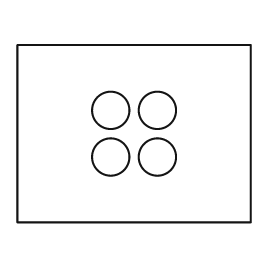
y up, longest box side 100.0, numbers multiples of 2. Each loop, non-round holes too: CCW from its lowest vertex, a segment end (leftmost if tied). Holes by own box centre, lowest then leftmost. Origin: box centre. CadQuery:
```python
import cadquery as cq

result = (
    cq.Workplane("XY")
    .moveTo(-50.0, -38.0)
    .lineTo(50.0, -38.0)
    .lineTo(50.0, 38.0)
    .lineTo(-50.0, 38.0)
    .close()
    .moveTo(-10.0, -10.0)
    .circle(8.0)
    .moveTo(10.0, -10.0)
    .circle(8.0)
    .moveTo(-10.0, 10.0)
    .circle(8.0)
    .moveTo(10.0, 10.0)
    .circle(8.0)
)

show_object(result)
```